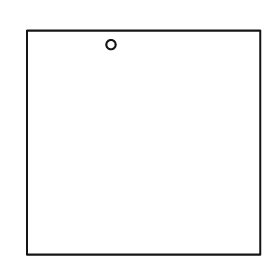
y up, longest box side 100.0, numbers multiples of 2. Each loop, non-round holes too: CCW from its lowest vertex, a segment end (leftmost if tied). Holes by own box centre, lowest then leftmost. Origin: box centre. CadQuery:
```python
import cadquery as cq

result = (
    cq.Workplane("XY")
    .moveTo(-50.0, -48.0)
    .lineTo(50.0, -48.0)
    .lineTo(50.0, 48.0)
    .lineTo(-50.0, 48.0)
    .close()
    .moveTo(-14.0, 42.0)
    .circle(2.0)
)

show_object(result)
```